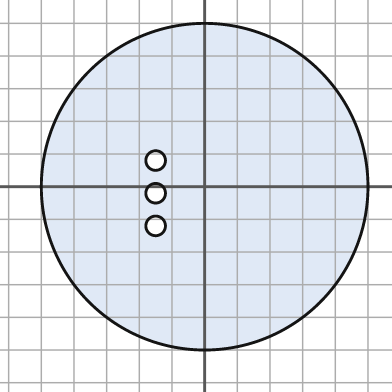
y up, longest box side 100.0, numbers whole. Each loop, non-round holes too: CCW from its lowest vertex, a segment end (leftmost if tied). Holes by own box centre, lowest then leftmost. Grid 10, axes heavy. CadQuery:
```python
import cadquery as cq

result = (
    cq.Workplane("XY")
    .moveTo(0.0, 0.0)
    .circle(50.0)
    .moveTo(-15.0, -12.0)
    .circle(3.0)
    .moveTo(-15.0, -2.0)
    .circle(3.0)
    .moveTo(-15.0, 8.0)
    .circle(3.0)
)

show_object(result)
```